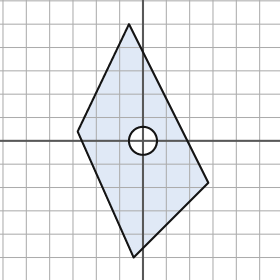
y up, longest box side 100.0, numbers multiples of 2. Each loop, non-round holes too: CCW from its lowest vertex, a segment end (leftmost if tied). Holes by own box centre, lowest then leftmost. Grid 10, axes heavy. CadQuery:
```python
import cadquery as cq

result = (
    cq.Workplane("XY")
    .moveTo(-4.0, -50.0)
    .lineTo(28.0, -18.0)
    .lineTo(-6.0, 50.0)
    .lineTo(-28.0, 4.0)
    .close()
    .moveTo(0.0, 0.0)
    .circle(6.0)
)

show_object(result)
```